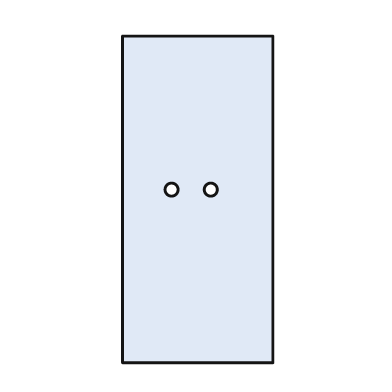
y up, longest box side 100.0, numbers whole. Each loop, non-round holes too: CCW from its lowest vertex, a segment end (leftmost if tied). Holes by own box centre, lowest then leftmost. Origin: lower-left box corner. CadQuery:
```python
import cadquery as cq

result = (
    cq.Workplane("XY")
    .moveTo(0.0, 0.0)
    .lineTo(46.0, 0.0)
    .lineTo(46.0, 100.0)
    .lineTo(0.0, 100.0)
    .close()
    .moveTo(15.0, 53.0)
    .circle(2.0)
    .moveTo(27.0, 53.0)
    .circle(2.0)
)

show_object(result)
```